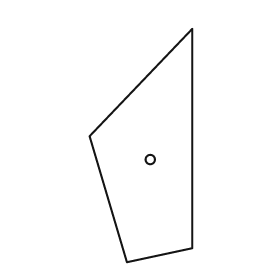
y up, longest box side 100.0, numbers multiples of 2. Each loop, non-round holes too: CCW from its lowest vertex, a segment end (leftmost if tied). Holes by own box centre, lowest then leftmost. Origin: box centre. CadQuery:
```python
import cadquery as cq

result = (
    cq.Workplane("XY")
    .moveTo(-6.0, -50.0)
    .lineTo(22.0, -44.0)
    .lineTo(22.0, 50.0)
    .lineTo(-22.0, 4.0)
    .close()
    .moveTo(4.0, -6.0)
    .circle(2.0)
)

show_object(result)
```